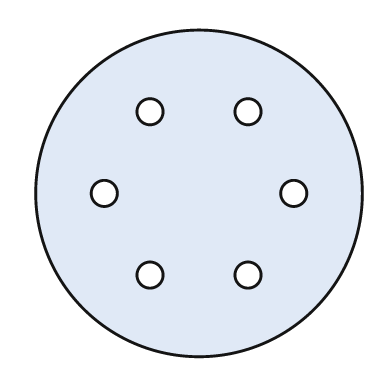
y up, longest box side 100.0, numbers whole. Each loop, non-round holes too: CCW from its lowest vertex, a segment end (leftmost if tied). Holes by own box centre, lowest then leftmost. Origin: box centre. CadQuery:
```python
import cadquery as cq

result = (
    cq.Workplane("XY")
    .moveTo(0.0, 0.0)
    .circle(50.0)
    .moveTo(-15.0, -25.0)
    .circle(4.0)
    .moveTo(15.0, -25.0)
    .circle(4.0)
    .moveTo(-29.0, 0.0)
    .circle(4.0)
    .moveTo(29.0, 0.0)
    .circle(4.0)
    .moveTo(-15.0, 25.0)
    .circle(4.0)
    .moveTo(15.0, 25.0)
    .circle(4.0)
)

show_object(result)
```